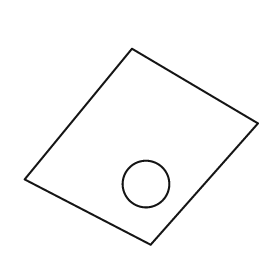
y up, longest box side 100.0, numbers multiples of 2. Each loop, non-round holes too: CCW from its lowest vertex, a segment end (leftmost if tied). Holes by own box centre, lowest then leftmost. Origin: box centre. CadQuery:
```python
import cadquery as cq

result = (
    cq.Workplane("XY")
    .moveTo(4.0, -42.0)
    .lineTo(50.0, 10.0)
    .lineTo(-4.0, 42.0)
    .lineTo(-50.0, -14.0)
    .close()
    .moveTo(2.0, -16.0)
    .circle(10.0)
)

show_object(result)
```